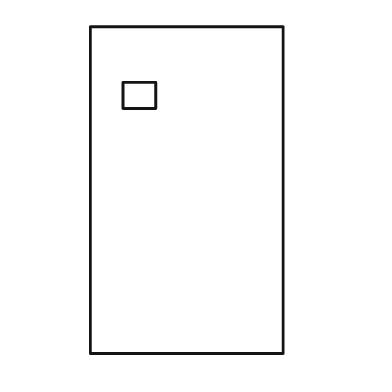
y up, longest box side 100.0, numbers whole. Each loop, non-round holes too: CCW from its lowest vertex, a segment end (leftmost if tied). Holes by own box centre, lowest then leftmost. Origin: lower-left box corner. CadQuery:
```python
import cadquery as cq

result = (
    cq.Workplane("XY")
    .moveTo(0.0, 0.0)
    .lineTo(59.0, 0.0)
    .lineTo(59.0, 100.0)
    .lineTo(0.0, 100.0)
    .close()
    .moveTo(10.0, 75.0)
    .lineTo(20.0, 75.0)
    .lineTo(20.0, 83.0)
    .lineTo(10.0, 83.0)
    .close()
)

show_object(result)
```